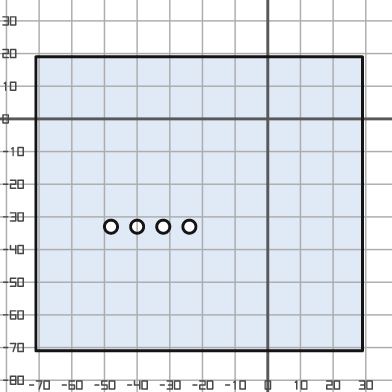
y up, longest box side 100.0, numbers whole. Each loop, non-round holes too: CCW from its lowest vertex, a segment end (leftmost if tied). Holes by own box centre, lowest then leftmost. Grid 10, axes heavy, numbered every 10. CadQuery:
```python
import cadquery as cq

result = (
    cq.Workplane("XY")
    .moveTo(-71.0, -71.0)
    .lineTo(29.0, -71.0)
    .lineTo(29.0, 19.0)
    .lineTo(-71.0, 19.0)
    .close()
    .moveTo(-48.0, -33.0)
    .circle(2.0)
    .moveTo(-40.0, -33.0)
    .circle(2.0)
    .moveTo(-32.0, -33.0)
    .circle(2.0)
    .moveTo(-24.0, -33.0)
    .circle(2.0)
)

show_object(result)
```